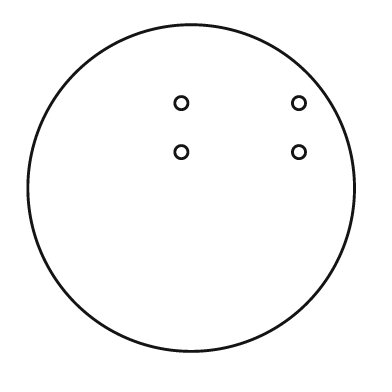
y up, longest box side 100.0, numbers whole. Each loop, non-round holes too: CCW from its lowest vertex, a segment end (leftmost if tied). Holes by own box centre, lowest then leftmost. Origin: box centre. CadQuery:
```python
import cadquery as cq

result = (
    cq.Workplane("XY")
    .moveTo(0.0, 0.0)
    .circle(50.0)
    .moveTo(-3.0, 11.0)
    .circle(2.0)
    .moveTo(33.0, 11.0)
    .circle(2.0)
    .moveTo(-3.0, 26.0)
    .circle(2.0)
    .moveTo(33.0, 26.0)
    .circle(2.0)
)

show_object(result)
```